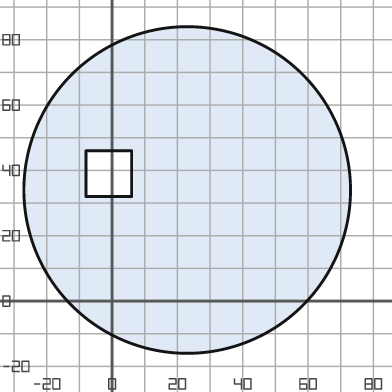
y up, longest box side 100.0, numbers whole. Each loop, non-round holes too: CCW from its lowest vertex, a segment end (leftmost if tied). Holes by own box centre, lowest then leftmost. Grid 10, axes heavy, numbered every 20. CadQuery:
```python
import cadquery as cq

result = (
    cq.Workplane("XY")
    .moveTo(23.0, 34.0)
    .circle(50.0)
    .moveTo(-8.0, 32.0)
    .lineTo(6.0, 32.0)
    .lineTo(6.0, 46.0)
    .lineTo(-8.0, 46.0)
    .close()
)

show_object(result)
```